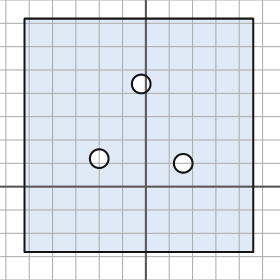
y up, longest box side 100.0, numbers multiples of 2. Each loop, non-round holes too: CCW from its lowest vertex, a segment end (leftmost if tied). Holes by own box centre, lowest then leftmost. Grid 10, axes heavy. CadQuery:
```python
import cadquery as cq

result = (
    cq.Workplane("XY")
    .moveTo(-52.0, -28.0)
    .lineTo(46.0, -28.0)
    .lineTo(46.0, 72.0)
    .lineTo(-52.0, 72.0)
    .close()
    .moveTo(16.0, 10.0)
    .circle(4.0)
    .moveTo(-20.0, 12.0)
    .circle(4.0)
    .moveTo(-2.0, 44.0)
    .circle(4.0)
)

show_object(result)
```